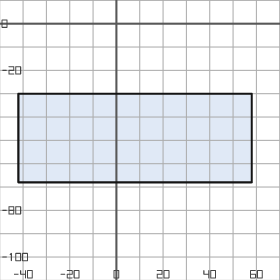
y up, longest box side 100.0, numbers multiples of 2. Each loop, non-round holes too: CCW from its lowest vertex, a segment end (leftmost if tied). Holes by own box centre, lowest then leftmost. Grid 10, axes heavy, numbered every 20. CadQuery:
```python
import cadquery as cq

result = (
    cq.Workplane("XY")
    .moveTo(-42.0, -68.0)
    .lineTo(58.0, -68.0)
    .lineTo(58.0, -30.0)
    .lineTo(-42.0, -30.0)
    .close()
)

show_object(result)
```